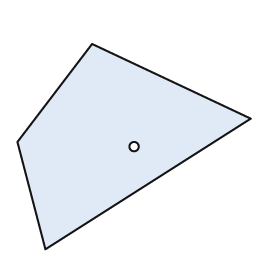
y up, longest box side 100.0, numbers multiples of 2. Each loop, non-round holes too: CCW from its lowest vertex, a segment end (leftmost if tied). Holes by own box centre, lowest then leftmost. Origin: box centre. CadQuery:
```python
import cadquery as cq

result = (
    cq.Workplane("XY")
    .moveTo(-38.0, -44.0)
    .lineTo(50.0, 12.0)
    .lineTo(-18.0, 44.0)
    .lineTo(-50.0, 2.0)
    .close()
    .moveTo(0.0, 0.0)
    .circle(2.0)
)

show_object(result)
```